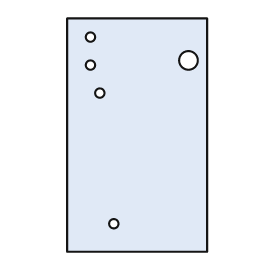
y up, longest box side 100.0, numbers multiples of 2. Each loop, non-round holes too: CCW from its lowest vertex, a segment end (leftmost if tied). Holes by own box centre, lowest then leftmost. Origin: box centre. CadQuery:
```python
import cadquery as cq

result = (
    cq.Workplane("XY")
    .moveTo(-30.0, -50.0)
    .lineTo(30.0, -50.0)
    .lineTo(30.0, 50.0)
    .lineTo(-30.0, 50.0)
    .close()
    .moveTo(-10.0, -38.0)
    .circle(2.0)
    .moveTo(-16.0, 18.0)
    .circle(2.0)
    .moveTo(-20.0, 30.0)
    .circle(2.0)
    .moveTo(22.0, 32.0)
    .circle(4.0)
    .moveTo(-20.0, 42.0)
    .circle(2.0)
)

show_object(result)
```